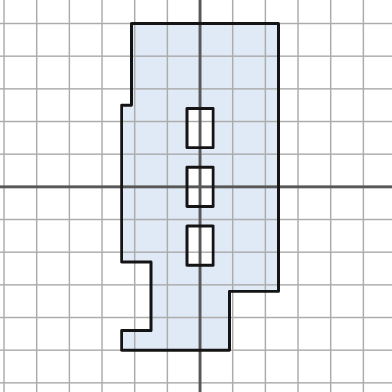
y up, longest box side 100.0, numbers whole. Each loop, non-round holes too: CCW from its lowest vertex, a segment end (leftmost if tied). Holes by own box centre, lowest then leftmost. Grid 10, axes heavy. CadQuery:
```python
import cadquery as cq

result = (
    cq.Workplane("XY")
    .moveTo(-24.0, -50.0)
    .lineTo(9.0, -50.0)
    .lineTo(9.0, -32.0)
    .lineTo(24.0, -32.0)
    .lineTo(24.0, 50.0)
    .lineTo(-21.0, 50.0)
    .lineTo(-21.0, 25.0)
    .lineTo(-24.0, 25.0)
    .lineTo(-24.0, -23.0)
    .lineTo(-15.0, -23.0)
    .lineTo(-15.0, -44.0)
    .lineTo(-24.0, -44.0)
    .close()
    .moveTo(-4.0, -24.0)
    .lineTo(4.0, -24.0)
    .lineTo(4.0, -12.0)
    .lineTo(-4.0, -12.0)
    .close()
    .moveTo(-4.0, -6.0)
    .lineTo(4.0, -6.0)
    .lineTo(4.0, 6.0)
    .lineTo(-4.0, 6.0)
    .close()
    .moveTo(-4.0, 12.0)
    .lineTo(4.0, 12.0)
    .lineTo(4.0, 24.0)
    .lineTo(-4.0, 24.0)
    .close()
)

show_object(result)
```